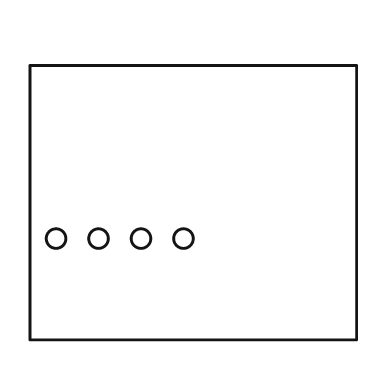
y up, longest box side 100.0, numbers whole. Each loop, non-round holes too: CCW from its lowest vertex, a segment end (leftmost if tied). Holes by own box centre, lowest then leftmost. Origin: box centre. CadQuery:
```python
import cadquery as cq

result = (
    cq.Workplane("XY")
    .moveTo(-50.0, -42.0)
    .lineTo(50.0, -42.0)
    .lineTo(50.0, 42.0)
    .lineTo(-50.0, 42.0)
    .close()
    .moveTo(-42.0, -11.0)
    .circle(3.0)
    .moveTo(-29.0, -11.0)
    .circle(3.0)
    .moveTo(-16.0, -11.0)
    .circle(3.0)
    .moveTo(-3.0, -11.0)
    .circle(3.0)
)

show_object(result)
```